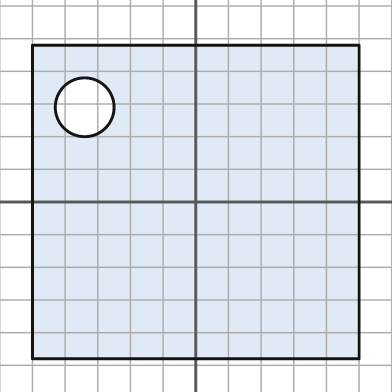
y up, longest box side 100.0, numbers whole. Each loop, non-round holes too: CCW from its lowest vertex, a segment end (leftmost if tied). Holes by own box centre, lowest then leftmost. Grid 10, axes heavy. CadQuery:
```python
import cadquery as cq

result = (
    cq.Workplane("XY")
    .moveTo(-50.0, -48.0)
    .lineTo(50.0, -48.0)
    .lineTo(50.0, 48.0)
    .lineTo(-50.0, 48.0)
    .close()
    .moveTo(-34.0, 29.0)
    .circle(9.0)
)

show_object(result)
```